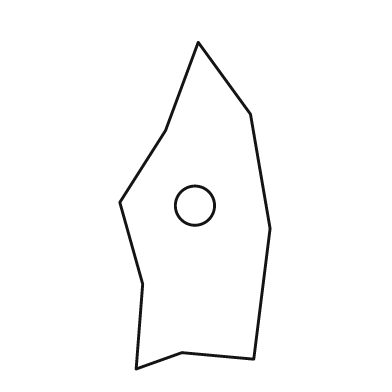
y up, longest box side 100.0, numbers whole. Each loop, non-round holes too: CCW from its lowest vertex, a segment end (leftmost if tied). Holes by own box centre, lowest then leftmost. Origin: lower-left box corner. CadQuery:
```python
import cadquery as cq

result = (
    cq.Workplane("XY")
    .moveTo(5.0, 0.0)
    .lineTo(19.0, 5.0)
    .lineTo(41.0, 3.0)
    .lineTo(46.0, 43.0)
    .lineTo(40.0, 78.0)
    .lineTo(24.0, 100.0)
    .lineTo(14.0, 73.0)
    .lineTo(0.0, 51.0)
    .lineTo(7.0, 26.0)
    .close()
    .moveTo(23.0, 50.0)
    .circle(6.0)
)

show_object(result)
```